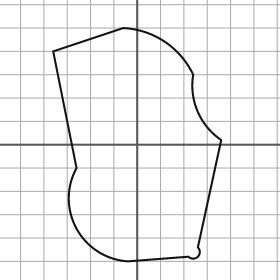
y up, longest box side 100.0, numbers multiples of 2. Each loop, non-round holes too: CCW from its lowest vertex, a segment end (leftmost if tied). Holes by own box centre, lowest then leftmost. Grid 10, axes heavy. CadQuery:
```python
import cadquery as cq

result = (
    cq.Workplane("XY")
    .moveTo(-4.0, -50.0)
    .lineTo(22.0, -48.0)
    .threePointArc((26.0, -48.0), (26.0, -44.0))
    .lineTo(36.0, 2.0)
    .threePointArc((26.0, 14.0), (24.0, 30.0))
    .threePointArc((12.0, 44.0), (-6.0, 50.0))
    .lineTo(-36.0, 40.0)
    .lineTo(-26.0, -10.0)
    .threePointArc((-26.0, -36.0), (-4.0, -50.0))
    .close()
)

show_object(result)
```